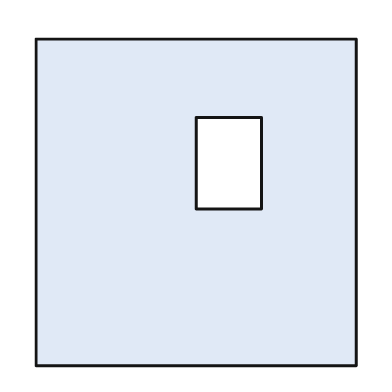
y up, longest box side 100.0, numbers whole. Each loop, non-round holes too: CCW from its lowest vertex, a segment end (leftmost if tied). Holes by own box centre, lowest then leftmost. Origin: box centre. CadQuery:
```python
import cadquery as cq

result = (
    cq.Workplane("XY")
    .moveTo(-49.0, -50.0)
    .lineTo(49.0, -50.0)
    .lineTo(49.0, 50.0)
    .lineTo(-49.0, 50.0)
    .close()
    .moveTo(0.0, -2.0)
    .lineTo(20.0, -2.0)
    .lineTo(20.0, 26.0)
    .lineTo(0.0, 26.0)
    .close()
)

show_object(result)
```